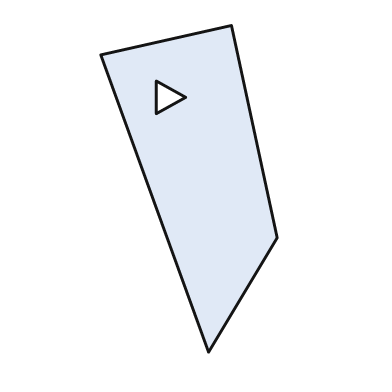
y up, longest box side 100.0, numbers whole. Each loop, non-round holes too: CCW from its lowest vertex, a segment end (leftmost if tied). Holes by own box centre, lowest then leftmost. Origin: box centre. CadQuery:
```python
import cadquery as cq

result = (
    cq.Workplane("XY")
    .moveTo(6.0, -50.0)
    .lineTo(27.0, -15.0)
    .lineTo(13.0, 50.0)
    .lineTo(-27.0, 41.0)
    .close()
    .moveTo(-10.0, 23.0)
    .lineTo(-1.0, 28.0)
    .lineTo(-10.0, 33.0)
    .close()
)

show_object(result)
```